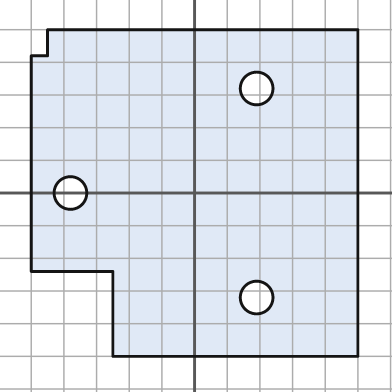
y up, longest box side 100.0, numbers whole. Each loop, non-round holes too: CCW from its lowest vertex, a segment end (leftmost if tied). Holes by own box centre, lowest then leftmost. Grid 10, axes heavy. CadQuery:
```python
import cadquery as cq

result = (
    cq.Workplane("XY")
    .moveTo(-25.0, -50.0)
    .lineTo(50.0, -50.0)
    .lineTo(50.0, 50.0)
    .lineTo(-45.0, 50.0)
    .lineTo(-45.0, 42.0)
    .lineTo(-50.0, 42.0)
    .lineTo(-50.0, -24.0)
    .lineTo(-25.0, -24.0)
    .close()
    .moveTo(19.0, -32.0)
    .circle(5.0)
    .moveTo(-38.0, 0.0)
    .circle(5.0)
    .moveTo(19.0, 32.0)
    .circle(5.0)
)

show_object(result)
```